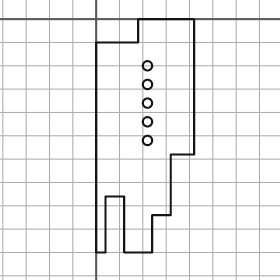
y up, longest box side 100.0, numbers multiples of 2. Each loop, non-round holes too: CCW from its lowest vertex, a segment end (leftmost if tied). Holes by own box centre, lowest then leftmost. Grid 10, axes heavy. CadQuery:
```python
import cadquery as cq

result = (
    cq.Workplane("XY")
    .moveTo(0.0, -100.0)
    .lineTo(4.0, -100.0)
    .lineTo(4.0, -76.0)
    .lineTo(12.0, -76.0)
    .lineTo(12.0, -100.0)
    .lineTo(24.0, -100.0)
    .lineTo(24.0, -84.0)
    .lineTo(32.0, -84.0)
    .lineTo(32.0, -58.0)
    .lineTo(42.0, -58.0)
    .lineTo(42.0, 0.0)
    .lineTo(18.0, 0.0)
    .lineTo(18.0, -10.0)
    .lineTo(0.0, -10.0)
    .close()
    .moveTo(22.0, -52.0)
    .circle(2.0)
    .moveTo(22.0, -44.0)
    .circle(2.0)
    .moveTo(22.0, -36.0)
    .circle(2.0)
    .moveTo(22.0, -28.0)
    .circle(2.0)
    .moveTo(22.0, -20.0)
    .circle(2.0)
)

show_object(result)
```